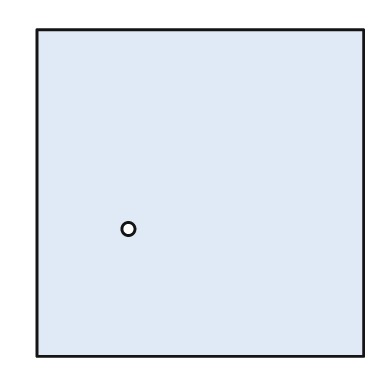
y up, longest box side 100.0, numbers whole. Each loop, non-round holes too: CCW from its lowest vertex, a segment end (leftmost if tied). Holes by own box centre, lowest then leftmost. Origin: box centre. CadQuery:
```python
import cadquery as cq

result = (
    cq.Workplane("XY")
    .moveTo(-50.0, -50.0)
    .lineTo(50.0, -50.0)
    .lineTo(50.0, 50.0)
    .lineTo(-50.0, 50.0)
    .close()
    .moveTo(-22.0, -11.0)
    .circle(2.0)
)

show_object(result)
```